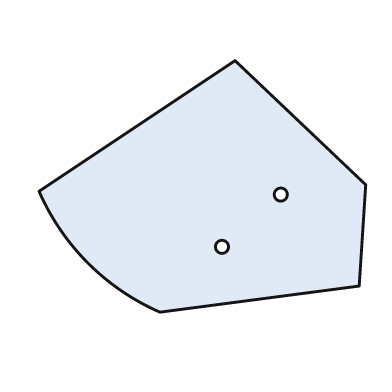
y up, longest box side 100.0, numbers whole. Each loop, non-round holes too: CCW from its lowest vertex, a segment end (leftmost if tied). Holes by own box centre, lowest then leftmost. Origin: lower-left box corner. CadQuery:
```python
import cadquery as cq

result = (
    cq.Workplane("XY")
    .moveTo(37.0, 0.0)
    .lineTo(98.0, 8.0)
    .lineTo(100.0, 39.0)
    .lineTo(60.0, 77.0)
    .lineTo(0.0, 37.0)
    .threePointArc((15.0, 15.0), (37.0, 0.0))
    .close()
    .moveTo(56.0, 20.0)
    .circle(2.0)
    .moveTo(74.0, 36.0)
    .circle(2.0)
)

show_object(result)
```